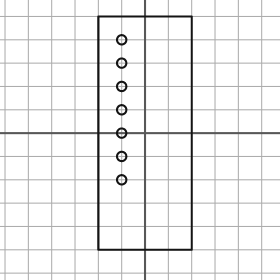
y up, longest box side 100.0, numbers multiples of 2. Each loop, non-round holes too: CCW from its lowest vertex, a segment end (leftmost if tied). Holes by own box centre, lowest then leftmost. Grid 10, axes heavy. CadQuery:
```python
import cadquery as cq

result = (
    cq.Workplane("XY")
    .moveTo(-20.0, -50.0)
    .lineTo(20.0, -50.0)
    .lineTo(20.0, 50.0)
    .lineTo(-20.0, 50.0)
    .close()
    .moveTo(-10.0, -20.0)
    .circle(2.0)
    .moveTo(-10.0, -10.0)
    .circle(2.0)
    .moveTo(-10.0, 0.0)
    .circle(2.0)
    .moveTo(-10.0, 10.0)
    .circle(2.0)
    .moveTo(-10.0, 20.0)
    .circle(2.0)
    .moveTo(-10.0, 30.0)
    .circle(2.0)
    .moveTo(-10.0, 40.0)
    .circle(2.0)
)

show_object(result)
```